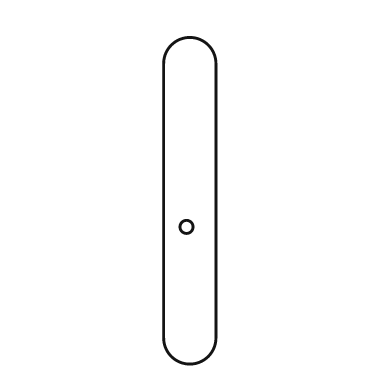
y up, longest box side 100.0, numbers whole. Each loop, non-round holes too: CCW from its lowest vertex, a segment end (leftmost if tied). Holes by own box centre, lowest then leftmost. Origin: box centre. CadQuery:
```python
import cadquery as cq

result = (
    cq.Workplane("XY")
    .moveTo(-8.0, -42.0)
    .threePointArc((0.0, -50.0), (8.0, -42.0))
    .lineTo(8.0, 42.0)
    .threePointArc((0.0, 50.0), (-8.0, 42.0))
    .close()
    .moveTo(-1.0, -8.0)
    .circle(2.0)
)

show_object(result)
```